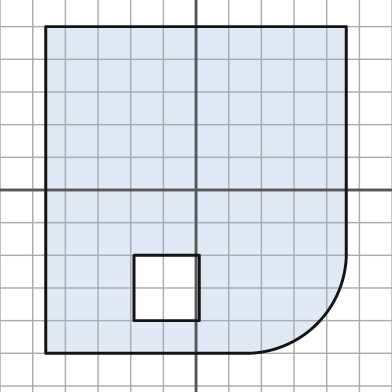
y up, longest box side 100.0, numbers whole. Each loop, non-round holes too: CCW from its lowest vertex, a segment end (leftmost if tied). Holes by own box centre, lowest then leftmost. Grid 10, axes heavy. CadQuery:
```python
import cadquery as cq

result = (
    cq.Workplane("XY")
    .moveTo(-46.0, -50.0)
    .lineTo(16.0, -50.0)
    .threePointArc((37.0, -41.0), (46.0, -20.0))
    .lineTo(46.0, 50.0)
    .lineTo(-46.0, 50.0)
    .close()
    .moveTo(-19.0, -40.0)
    .lineTo(1.0, -40.0)
    .lineTo(1.0, -20.0)
    .lineTo(-19.0, -20.0)
    .close()
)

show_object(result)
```